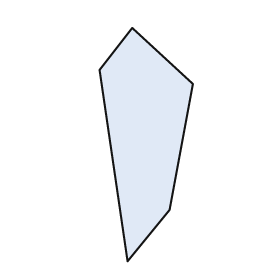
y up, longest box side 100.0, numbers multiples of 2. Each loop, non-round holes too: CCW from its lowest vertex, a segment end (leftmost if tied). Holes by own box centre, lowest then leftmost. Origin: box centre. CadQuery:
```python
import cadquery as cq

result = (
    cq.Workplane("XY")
    .moveTo(-8.0, -50.0)
    .lineTo(10.0, -28.0)
    .lineTo(20.0, 26.0)
    .lineTo(-6.0, 50.0)
    .lineTo(-20.0, 32.0)
    .close()
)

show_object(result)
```